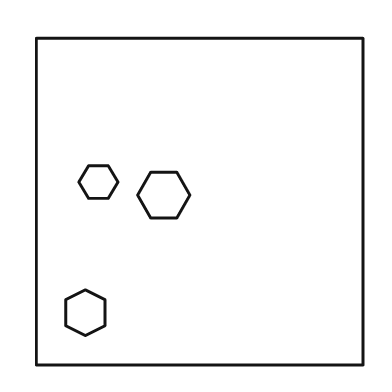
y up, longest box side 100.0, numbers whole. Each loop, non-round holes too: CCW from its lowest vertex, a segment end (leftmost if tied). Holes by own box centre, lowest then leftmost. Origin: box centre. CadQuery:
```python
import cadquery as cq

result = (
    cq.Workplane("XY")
    .moveTo(-50.0, -50.0)
    .lineTo(50.0, -50.0)
    .lineTo(50.0, 50.0)
    .lineTo(-50.0, 50.0)
    .close()
    .moveTo(-35.0, -41.0)
    .lineTo(-29.0, -38.0)
    .lineTo(-29.0, -30.0)
    .lineTo(-35.0, -27.0)
    .lineTo(-41.0, -30.0)
    .lineTo(-41.0, -38.0)
    .close()
    .moveTo(-15.0, -5.0)
    .lineTo(-7.0, -5.0)
    .lineTo(-3.0, 2.0)
    .lineTo(-7.0, 9.0)
    .lineTo(-15.0, 9.0)
    .lineTo(-19.0, 2.0)
    .close()
    .moveTo(-34.0, 1.0)
    .lineTo(-28.0, 1.0)
    .lineTo(-25.0, 6.0)
    .lineTo(-28.0, 11.0)
    .lineTo(-34.0, 11.0)
    .lineTo(-37.0, 6.0)
    .close()
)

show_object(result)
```